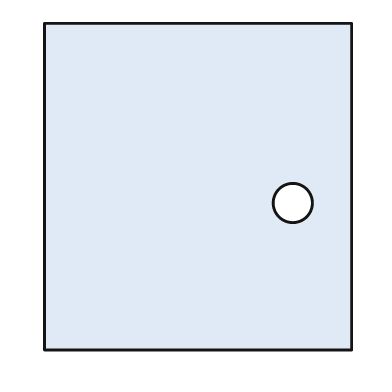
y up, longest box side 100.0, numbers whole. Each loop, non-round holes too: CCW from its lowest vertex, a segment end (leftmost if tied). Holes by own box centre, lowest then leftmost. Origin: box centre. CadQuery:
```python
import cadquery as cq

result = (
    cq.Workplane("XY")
    .moveTo(-47.0, -50.0)
    .lineTo(47.0, -50.0)
    .lineTo(47.0, 50.0)
    .lineTo(-47.0, 50.0)
    .close()
    .moveTo(29.0, -5.0)
    .circle(6.0)
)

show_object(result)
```